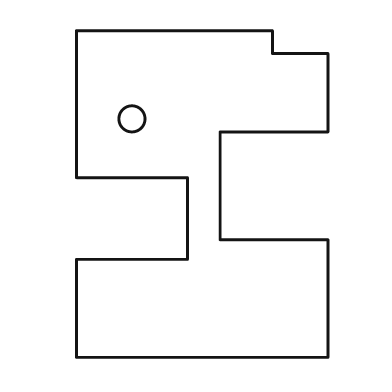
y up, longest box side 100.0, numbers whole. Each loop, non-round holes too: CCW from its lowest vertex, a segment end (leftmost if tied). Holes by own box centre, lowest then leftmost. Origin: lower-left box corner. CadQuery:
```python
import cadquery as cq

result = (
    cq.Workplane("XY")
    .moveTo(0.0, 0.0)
    .lineTo(77.0, 0.0)
    .lineTo(77.0, 36.0)
    .lineTo(44.0, 36.0)
    .lineTo(44.0, 69.0)
    .lineTo(77.0, 69.0)
    .lineTo(77.0, 93.0)
    .lineTo(60.0, 93.0)
    .lineTo(60.0, 100.0)
    .lineTo(0.0, 100.0)
    .lineTo(0.0, 55.0)
    .lineTo(34.0, 55.0)
    .lineTo(34.0, 30.0)
    .lineTo(0.0, 30.0)
    .close()
    .moveTo(17.0, 73.0)
    .circle(4.0)
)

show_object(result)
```